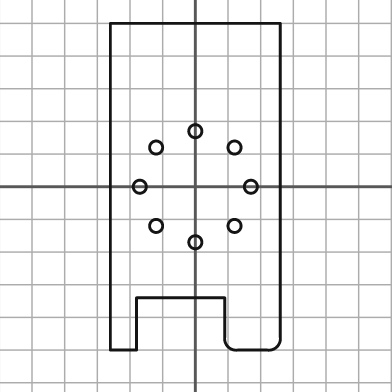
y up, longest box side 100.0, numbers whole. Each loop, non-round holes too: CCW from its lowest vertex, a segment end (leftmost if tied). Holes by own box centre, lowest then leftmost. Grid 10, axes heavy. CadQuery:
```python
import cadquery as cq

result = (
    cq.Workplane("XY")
    .moveTo(-26.0, -50.0)
    .lineTo(-18.0, -50.0)
    .lineTo(-18.0, -34.0)
    .lineTo(9.0, -34.0)
    .lineTo(9.0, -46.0)
    .threePointArc((10.0, -49.0), (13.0, -50.0))
    .lineTo(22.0, -50.0)
    .threePointArc((25.0, -49.0), (26.0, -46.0))
    .lineTo(26.0, 50.0)
    .lineTo(-26.0, 50.0)
    .close()
    .moveTo(0.0, -17.0)
    .circle(2.0)
    .moveTo(-12.0, -12.0)
    .circle(2.0)
    .moveTo(12.0, -12.0)
    .circle(2.0)
    .moveTo(-17.0, 0.0)
    .circle(2.0)
    .moveTo(17.0, 0.0)
    .circle(2.0)
    .moveTo(-12.0, 12.0)
    .circle(2.0)
    .moveTo(12.0, 12.0)
    .circle(2.0)
    .moveTo(0.0, 17.0)
    .circle(2.0)
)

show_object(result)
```